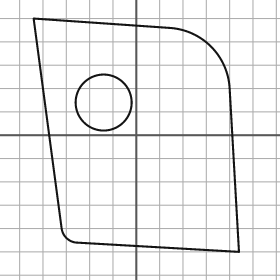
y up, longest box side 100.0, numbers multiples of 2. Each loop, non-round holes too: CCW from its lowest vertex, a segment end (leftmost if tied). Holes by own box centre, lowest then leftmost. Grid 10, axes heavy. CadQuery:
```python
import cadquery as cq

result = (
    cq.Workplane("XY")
    .moveTo(44.0, -50.0)
    .lineTo(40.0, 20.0)
    .threePointArc((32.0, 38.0), (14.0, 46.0))
    .lineTo(-44.0, 50.0)
    .lineTo(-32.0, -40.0)
    .threePointArc((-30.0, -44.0), (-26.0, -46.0))
    .close()
    .moveTo(-14.0, 14.0)
    .circle(12.0)
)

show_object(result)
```